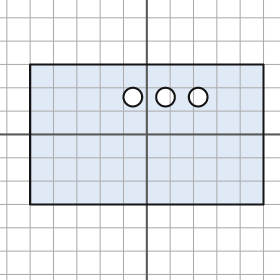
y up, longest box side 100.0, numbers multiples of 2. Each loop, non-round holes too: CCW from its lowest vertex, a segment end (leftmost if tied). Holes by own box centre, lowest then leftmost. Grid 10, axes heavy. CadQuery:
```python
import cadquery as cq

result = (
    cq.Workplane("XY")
    .moveTo(-50.0, -30.0)
    .lineTo(50.0, -30.0)
    .lineTo(50.0, 30.0)
    .lineTo(-50.0, 30.0)
    .close()
    .moveTo(-6.0, 16.0)
    .circle(4.0)
    .moveTo(8.0, 16.0)
    .circle(4.0)
    .moveTo(22.0, 16.0)
    .circle(4.0)
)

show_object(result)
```